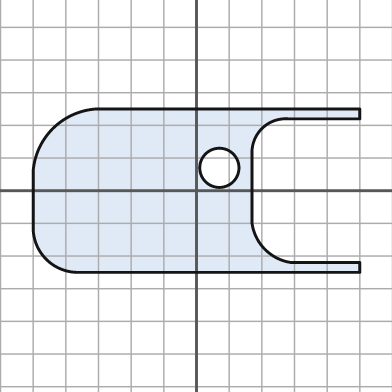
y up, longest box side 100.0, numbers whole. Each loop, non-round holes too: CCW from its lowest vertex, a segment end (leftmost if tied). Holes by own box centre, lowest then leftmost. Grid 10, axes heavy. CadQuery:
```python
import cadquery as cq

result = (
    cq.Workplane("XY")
    .moveTo(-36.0, -25.0)
    .lineTo(50.0, -25.0)
    .lineTo(50.0, -22.0)
    .lineTo(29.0, -22.0)
    .threePointArc((21.0, -18.0), (17.0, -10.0))
    .lineTo(17.0, 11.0)
    .threePointArc((20.0, 19.0), (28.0, 22.0))
    .lineTo(50.0, 22.0)
    .lineTo(50.0, 25.0)
    .lineTo(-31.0, 25.0)
    .threePointArc((-44.0, 19.0), (-50.0, 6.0))
    .lineTo(-50.0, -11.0)
    .threePointArc((-46.0, -21.0), (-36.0, -25.0))
    .close()
    .moveTo(7.0, 7.0)
    .circle(6.0)
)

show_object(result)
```